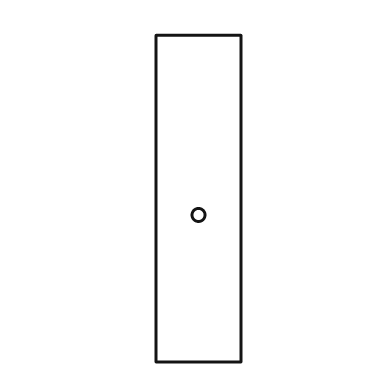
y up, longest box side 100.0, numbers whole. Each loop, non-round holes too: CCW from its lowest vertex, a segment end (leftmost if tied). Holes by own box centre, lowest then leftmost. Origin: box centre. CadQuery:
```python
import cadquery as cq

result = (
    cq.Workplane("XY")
    .moveTo(-13.0, -50.0)
    .lineTo(13.0, -50.0)
    .lineTo(13.0, 50.0)
    .lineTo(-13.0, 50.0)
    .close()
    .moveTo(0.0, -5.0)
    .circle(2.0)
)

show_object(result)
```